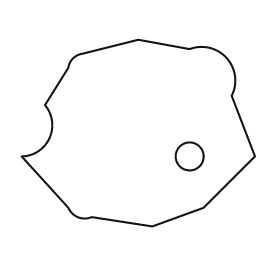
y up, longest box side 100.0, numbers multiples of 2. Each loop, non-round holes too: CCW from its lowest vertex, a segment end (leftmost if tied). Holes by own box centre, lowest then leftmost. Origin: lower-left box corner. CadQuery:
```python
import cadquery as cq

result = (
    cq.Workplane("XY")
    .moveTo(56.0, 0.0)
    .lineTo(78.0, 8.0)
    .lineTo(100.0, 30.0)
    .lineTo(90.0, 56.0)
    .threePointArc((88.0, 72.0), (72.0, 76.0))
    .lineTo(50.0, 80.0)
    .lineTo(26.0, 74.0)
    .threePointArc((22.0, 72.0), (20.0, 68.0))
    .lineTo(10.0, 52.0)
    .threePointArc((12.0, 38.0), (0.0, 30.0))
    .lineTo(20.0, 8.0)
    .threePointArc((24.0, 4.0), (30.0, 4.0))
    .close()
    .moveTo(72.0, 30.0)
    .circle(6.0)
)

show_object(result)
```